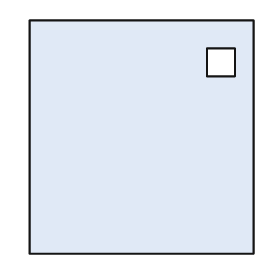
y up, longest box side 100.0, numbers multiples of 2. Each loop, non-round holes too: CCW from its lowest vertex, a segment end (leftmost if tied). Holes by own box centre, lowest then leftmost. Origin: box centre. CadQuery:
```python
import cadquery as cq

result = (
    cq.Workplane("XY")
    .moveTo(-48.0, -50.0)
    .lineTo(48.0, -50.0)
    .lineTo(48.0, 50.0)
    .lineTo(-48.0, 50.0)
    .close()
    .moveTo(28.0, 26.0)
    .lineTo(40.0, 26.0)
    .lineTo(40.0, 38.0)
    .lineTo(28.0, 38.0)
    .close()
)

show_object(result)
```